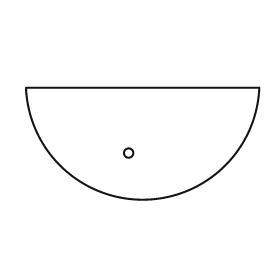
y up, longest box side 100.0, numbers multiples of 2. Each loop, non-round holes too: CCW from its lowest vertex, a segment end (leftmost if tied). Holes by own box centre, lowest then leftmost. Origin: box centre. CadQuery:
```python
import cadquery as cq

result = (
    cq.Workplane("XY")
    .moveTo(-50.0, 24.0)
    .threePointArc((0.0, -24.0), (50.0, 24.0))
    .close()
    .moveTo(-6.0, -4.0)
    .circle(2.0)
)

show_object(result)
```